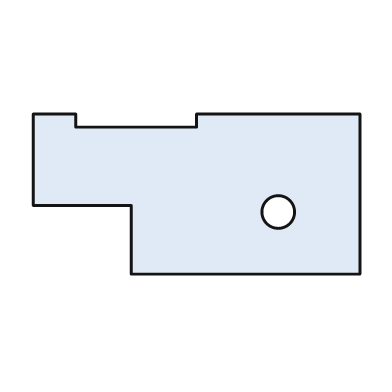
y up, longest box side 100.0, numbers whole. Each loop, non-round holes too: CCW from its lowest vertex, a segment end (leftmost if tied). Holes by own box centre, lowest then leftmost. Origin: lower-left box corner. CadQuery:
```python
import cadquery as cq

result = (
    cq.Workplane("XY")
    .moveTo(30.0, 0.0)
    .lineTo(100.0, 0.0)
    .lineTo(100.0, 49.0)
    .lineTo(50.0, 49.0)
    .lineTo(50.0, 45.0)
    .lineTo(13.0, 45.0)
    .lineTo(13.0, 49.0)
    .lineTo(0.0, 49.0)
    .lineTo(0.0, 21.0)
    .lineTo(30.0, 21.0)
    .close()
    .moveTo(75.0, 19.0)
    .circle(5.0)
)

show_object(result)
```